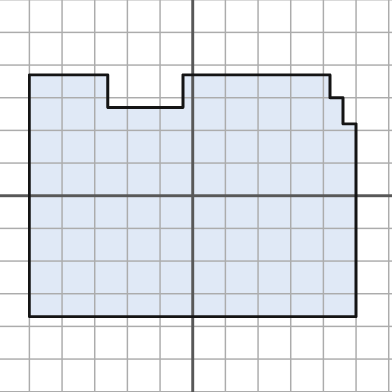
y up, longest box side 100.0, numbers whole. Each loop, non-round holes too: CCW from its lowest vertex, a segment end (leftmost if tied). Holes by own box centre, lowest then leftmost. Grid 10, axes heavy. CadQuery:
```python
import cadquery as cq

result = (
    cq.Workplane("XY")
    .moveTo(-50.0, -37.0)
    .lineTo(50.0, -37.0)
    .lineTo(50.0, 22.0)
    .lineTo(46.0, 22.0)
    .lineTo(46.0, 30.0)
    .lineTo(42.0, 30.0)
    .lineTo(42.0, 37.0)
    .lineTo(-3.0, 37.0)
    .lineTo(-3.0, 27.0)
    .lineTo(-26.0, 27.0)
    .lineTo(-26.0, 37.0)
    .lineTo(-50.0, 37.0)
    .close()
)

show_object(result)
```